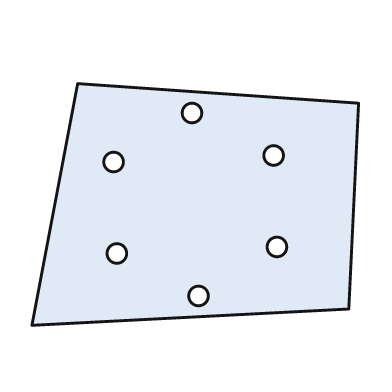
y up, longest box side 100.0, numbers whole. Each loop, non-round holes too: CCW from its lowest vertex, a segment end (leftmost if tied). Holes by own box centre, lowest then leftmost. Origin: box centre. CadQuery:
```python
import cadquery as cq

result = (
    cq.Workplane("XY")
    .moveTo(-50.0, -37.0)
    .lineTo(47.0, -32.0)
    .lineTo(50.0, 31.0)
    .lineTo(-36.0, 37.0)
    .close()
    .moveTo(1.0, -28.0)
    .circle(3.0)
    .moveTo(-24.0, -15.0)
    .circle(3.0)
    .moveTo(25.0, -13.0)
    .circle(3.0)
    .moveTo(-25.0, 13.0)
    .circle(3.0)
    .moveTo(24.0, 15.0)
    .circle(3.0)
    .moveTo(-1.0, 28.0)
    .circle(3.0)
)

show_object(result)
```